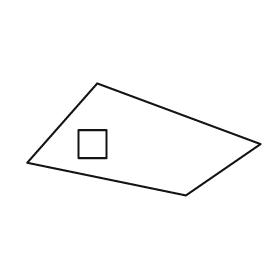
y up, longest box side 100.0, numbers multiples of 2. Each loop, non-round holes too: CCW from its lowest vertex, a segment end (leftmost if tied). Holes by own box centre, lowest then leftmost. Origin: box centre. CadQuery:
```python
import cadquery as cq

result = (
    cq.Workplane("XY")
    .moveTo(18.0, -24.0)
    .lineTo(50.0, -2.0)
    .lineTo(-20.0, 24.0)
    .lineTo(-50.0, -10.0)
    .close()
    .moveTo(-28.0, -8.0)
    .lineTo(-16.0, -8.0)
    .lineTo(-16.0, 4.0)
    .lineTo(-28.0, 4.0)
    .close()
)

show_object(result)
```